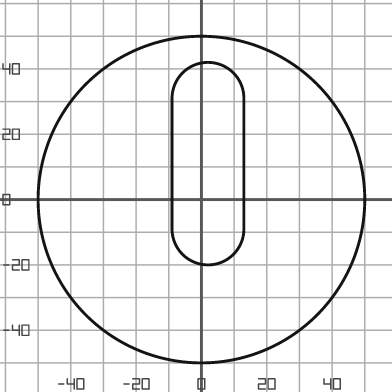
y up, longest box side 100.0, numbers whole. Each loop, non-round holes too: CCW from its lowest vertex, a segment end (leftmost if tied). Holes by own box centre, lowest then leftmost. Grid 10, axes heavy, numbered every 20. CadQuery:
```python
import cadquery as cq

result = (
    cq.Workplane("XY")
    .moveTo(0.0, 0.0)
    .circle(50.0)
    .moveTo(-9.0, -9.0)
    .threePointArc((2.0, -20.0), (13.0, -9.0))
    .lineTo(13.0, 31.0)
    .threePointArc((2.0, 42.0), (-9.0, 31.0))
    .close()
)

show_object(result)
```